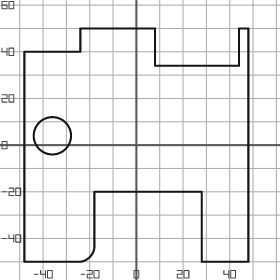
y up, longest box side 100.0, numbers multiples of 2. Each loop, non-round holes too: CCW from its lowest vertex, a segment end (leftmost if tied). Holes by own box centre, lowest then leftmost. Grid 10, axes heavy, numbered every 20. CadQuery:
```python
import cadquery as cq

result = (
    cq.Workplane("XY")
    .moveTo(-48.0, -50.0)
    .lineTo(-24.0, -50.0)
    .threePointArc((-20.0, -48.0), (-18.0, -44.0))
    .lineTo(-18.0, -20.0)
    .lineTo(28.0, -20.0)
    .lineTo(28.0, -50.0)
    .lineTo(48.0, -50.0)
    .lineTo(48.0, 50.0)
    .lineTo(44.0, 50.0)
    .lineTo(44.0, 34.0)
    .lineTo(8.0, 34.0)
    .lineTo(8.0, 50.0)
    .lineTo(-24.0, 50.0)
    .lineTo(-24.0, 40.0)
    .lineTo(-48.0, 40.0)
    .close()
    .moveTo(-36.0, 4.0)
    .circle(8.0)
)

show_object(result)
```